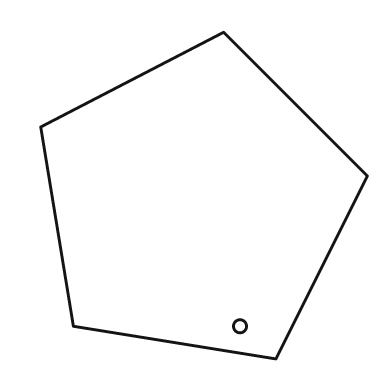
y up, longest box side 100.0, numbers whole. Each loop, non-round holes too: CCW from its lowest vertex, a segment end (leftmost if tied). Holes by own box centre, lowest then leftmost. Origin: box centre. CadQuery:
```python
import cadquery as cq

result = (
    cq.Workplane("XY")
    .moveTo(22.0, -50.0)
    .lineTo(50.0, 6.0)
    .lineTo(6.0, 50.0)
    .lineTo(-50.0, 21.0)
    .lineTo(-40.0, -40.0)
    .close()
    .moveTo(11.0, -40.0)
    .circle(2.0)
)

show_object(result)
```